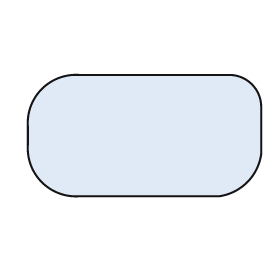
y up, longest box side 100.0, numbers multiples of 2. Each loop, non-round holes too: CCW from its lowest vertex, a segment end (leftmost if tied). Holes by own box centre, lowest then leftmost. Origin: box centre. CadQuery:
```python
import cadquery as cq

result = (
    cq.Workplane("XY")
    .moveTo(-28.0, -26.0)
    .lineTo(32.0, -26.0)
    .threePointArc((44.0, -20.0), (50.0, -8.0))
    .lineTo(50.0, 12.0)
    .threePointArc((46.0, 22.0), (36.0, 26.0))
    .lineTo(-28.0, 26.0)
    .threePointArc((-44.0, 20.0), (-50.0, 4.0))
    .lineTo(-50.0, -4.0)
    .threePointArc((-44.0, -20.0), (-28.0, -26.0))
    .close()
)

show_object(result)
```